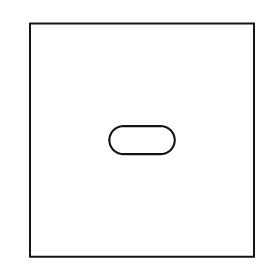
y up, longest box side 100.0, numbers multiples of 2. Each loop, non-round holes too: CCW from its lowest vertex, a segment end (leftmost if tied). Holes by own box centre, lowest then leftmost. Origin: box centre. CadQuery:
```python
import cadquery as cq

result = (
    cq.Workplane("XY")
    .moveTo(-48.0, -50.0)
    .lineTo(48.0, -50.0)
    .lineTo(48.0, 50.0)
    .lineTo(-48.0, 50.0)
    .close()
    .moveTo(-8.0, -6.0)
    .lineTo(8.0, -6.0)
    .threePointArc((14.0, 0.0), (8.0, 6.0))
    .lineTo(-8.0, 6.0)
    .threePointArc((-14.0, 0.0), (-8.0, -6.0))
    .close()
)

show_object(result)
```